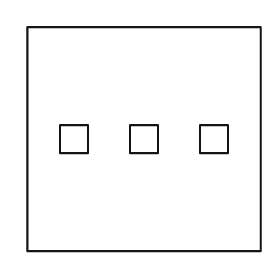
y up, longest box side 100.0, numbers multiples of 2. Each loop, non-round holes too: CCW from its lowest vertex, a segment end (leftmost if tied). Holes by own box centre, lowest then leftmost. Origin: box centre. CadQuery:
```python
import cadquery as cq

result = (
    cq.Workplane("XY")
    .moveTo(-50.0, -48.0)
    .lineTo(50.0, -48.0)
    .lineTo(50.0, 48.0)
    .lineTo(-50.0, 48.0)
    .close()
    .moveTo(-36.0, -6.0)
    .lineTo(-24.0, -6.0)
    .lineTo(-24.0, 6.0)
    .lineTo(-36.0, 6.0)
    .close()
    .moveTo(-6.0, -6.0)
    .lineTo(6.0, -6.0)
    .lineTo(6.0, 6.0)
    .lineTo(-6.0, 6.0)
    .close()
    .moveTo(24.0, -6.0)
    .lineTo(36.0, -6.0)
    .lineTo(36.0, 6.0)
    .lineTo(24.0, 6.0)
    .close()
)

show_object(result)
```